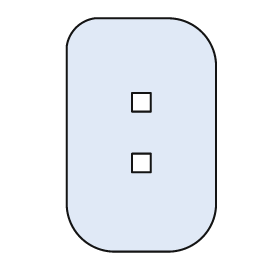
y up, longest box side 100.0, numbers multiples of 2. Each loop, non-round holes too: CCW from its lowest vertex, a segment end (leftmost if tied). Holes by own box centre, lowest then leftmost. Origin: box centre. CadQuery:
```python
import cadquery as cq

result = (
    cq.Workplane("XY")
    .moveTo(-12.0, -50.0)
    .lineTo(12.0, -50.0)
    .threePointArc((26.0, -44.0), (32.0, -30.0))
    .lineTo(32.0, 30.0)
    .threePointArc((26.0, 44.0), (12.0, 50.0))
    .lineTo(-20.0, 50.0)
    .threePointArc((-28.0, 46.0), (-32.0, 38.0))
    .lineTo(-32.0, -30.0)
    .threePointArc((-26.0, -44.0), (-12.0, -50.0))
    .close()
    .moveTo(-4.0, -16.0)
    .lineTo(4.0, -16.0)
    .lineTo(4.0, -8.0)
    .lineTo(-4.0, -8.0)
    .close()
    .moveTo(-4.0, 10.0)
    .lineTo(4.0, 10.0)
    .lineTo(4.0, 18.0)
    .lineTo(-4.0, 18.0)
    .close()
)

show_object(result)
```